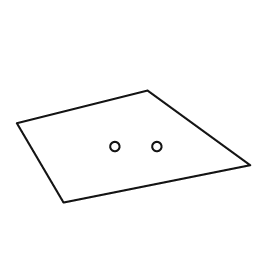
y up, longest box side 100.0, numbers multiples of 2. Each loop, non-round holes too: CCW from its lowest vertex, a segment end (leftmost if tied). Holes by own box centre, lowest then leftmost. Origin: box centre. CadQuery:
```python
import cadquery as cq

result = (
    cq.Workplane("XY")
    .moveTo(-30.0, -24.0)
    .lineTo(50.0, -8.0)
    .lineTo(6.0, 24.0)
    .lineTo(-50.0, 10.0)
    .close()
    .moveTo(-8.0, 0.0)
    .circle(2.0)
    .moveTo(10.0, 0.0)
    .circle(2.0)
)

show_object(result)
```